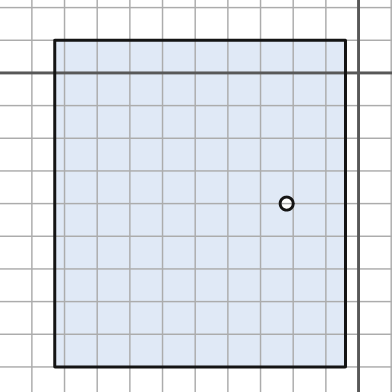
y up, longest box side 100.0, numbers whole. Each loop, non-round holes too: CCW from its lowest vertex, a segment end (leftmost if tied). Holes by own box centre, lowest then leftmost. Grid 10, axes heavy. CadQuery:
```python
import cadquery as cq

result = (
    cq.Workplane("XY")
    .moveTo(-93.0, -90.0)
    .lineTo(-4.0, -90.0)
    .lineTo(-4.0, 10.0)
    .lineTo(-93.0, 10.0)
    .close()
    .moveTo(-22.0, -40.0)
    .circle(2.0)
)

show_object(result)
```